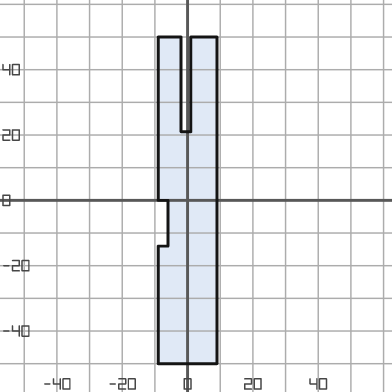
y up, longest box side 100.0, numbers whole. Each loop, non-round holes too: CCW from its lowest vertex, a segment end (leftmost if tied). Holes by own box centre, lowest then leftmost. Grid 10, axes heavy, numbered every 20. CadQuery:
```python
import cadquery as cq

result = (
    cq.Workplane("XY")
    .moveTo(-9.0, -50.0)
    .lineTo(9.0, -50.0)
    .lineTo(9.0, 50.0)
    .lineTo(1.0, 50.0)
    .lineTo(1.0, 21.0)
    .lineTo(-2.0, 21.0)
    .lineTo(-2.0, 50.0)
    .lineTo(-9.0, 50.0)
    .lineTo(-9.0, 0.0)
    .lineTo(-6.0, 0.0)
    .lineTo(-6.0, -14.0)
    .lineTo(-9.0, -14.0)
    .close()
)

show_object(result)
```